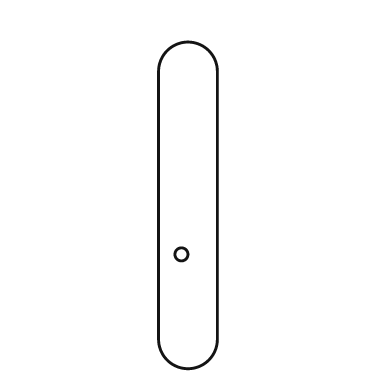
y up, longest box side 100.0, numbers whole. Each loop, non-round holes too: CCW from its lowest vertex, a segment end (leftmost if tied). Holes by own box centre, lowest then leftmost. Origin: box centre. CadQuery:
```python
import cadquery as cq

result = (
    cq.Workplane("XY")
    .moveTo(-9.0, -41.0)
    .threePointArc((0.0, -50.0), (9.0, -41.0))
    .lineTo(9.0, 41.0)
    .threePointArc((0.0, 50.0), (-9.0, 41.0))
    .close()
    .moveTo(-2.0, -15.0)
    .circle(2.0)
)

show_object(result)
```